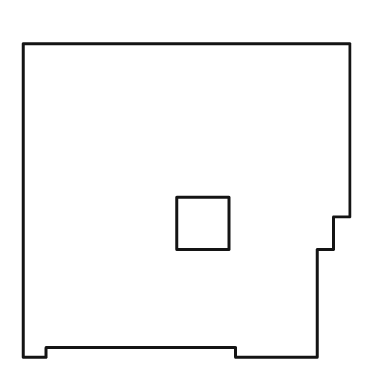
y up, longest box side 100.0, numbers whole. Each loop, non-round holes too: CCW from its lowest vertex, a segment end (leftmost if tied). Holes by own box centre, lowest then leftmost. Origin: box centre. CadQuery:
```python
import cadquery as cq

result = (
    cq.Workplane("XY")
    .moveTo(-50.0, -48.0)
    .lineTo(-43.0, -48.0)
    .lineTo(-43.0, -45.0)
    .lineTo(15.0, -45.0)
    .lineTo(15.0, -48.0)
    .lineTo(40.0, -48.0)
    .lineTo(40.0, -15.0)
    .lineTo(45.0, -15.0)
    .lineTo(45.0, -5.0)
    .lineTo(50.0, -5.0)
    .lineTo(50.0, 48.0)
    .lineTo(-50.0, 48.0)
    .close()
    .moveTo(-3.0, -15.0)
    .lineTo(13.0, -15.0)
    .lineTo(13.0, 1.0)
    .lineTo(-3.0, 1.0)
    .close()
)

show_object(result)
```